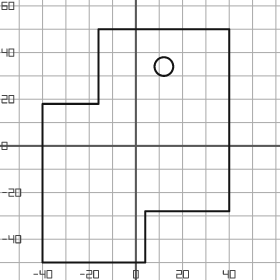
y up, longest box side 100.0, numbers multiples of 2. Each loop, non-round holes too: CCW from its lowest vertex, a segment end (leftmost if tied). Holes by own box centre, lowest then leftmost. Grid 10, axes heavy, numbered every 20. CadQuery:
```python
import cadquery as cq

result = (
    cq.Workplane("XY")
    .moveTo(-40.0, -50.0)
    .lineTo(4.0, -50.0)
    .lineTo(4.0, -28.0)
    .lineTo(40.0, -28.0)
    .lineTo(40.0, 50.0)
    .lineTo(-16.0, 50.0)
    .lineTo(-16.0, 18.0)
    .lineTo(-40.0, 18.0)
    .close()
    .moveTo(12.0, 34.0)
    .circle(4.0)
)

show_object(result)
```